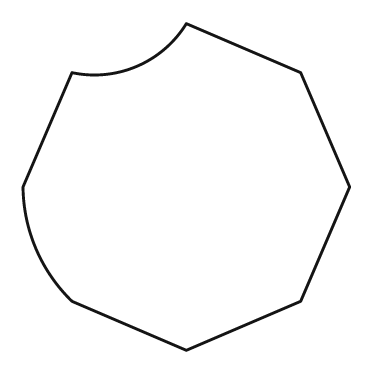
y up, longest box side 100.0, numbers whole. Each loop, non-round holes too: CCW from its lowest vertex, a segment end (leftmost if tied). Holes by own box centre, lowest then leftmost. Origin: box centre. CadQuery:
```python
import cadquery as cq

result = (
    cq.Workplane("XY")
    .moveTo(0.0, -50.0)
    .lineTo(35.0, -35.0)
    .lineTo(50.0, 0.0)
    .lineTo(35.0, 35.0)
    .lineTo(0.0, 50.0)
    .threePointArc((-15.0, 37.0), (-35.0, 35.0))
    .lineTo(-50.0, 0.0)
    .threePointArc((-46.0, -19.0), (-35.0, -35.0))
    .close()
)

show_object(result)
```